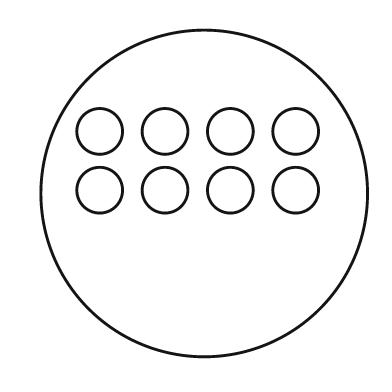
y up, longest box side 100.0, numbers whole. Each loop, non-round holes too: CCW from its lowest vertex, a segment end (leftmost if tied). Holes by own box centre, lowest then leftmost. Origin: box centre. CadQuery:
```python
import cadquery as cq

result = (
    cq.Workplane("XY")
    .moveTo(0.0, 0.0)
    .circle(50.0)
    .moveTo(-32.0, 1.0)
    .circle(7.0)
    .moveTo(-12.0, 1.0)
    .circle(7.0)
    .moveTo(8.0, 1.0)
    .circle(7.0)
    .moveTo(28.0, 1.0)
    .circle(7.0)
    .moveTo(-32.0, 19.0)
    .circle(7.0)
    .moveTo(-12.0, 19.0)
    .circle(7.0)
    .moveTo(8.0, 19.0)
    .circle(7.0)
    .moveTo(28.0, 19.0)
    .circle(7.0)
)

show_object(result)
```